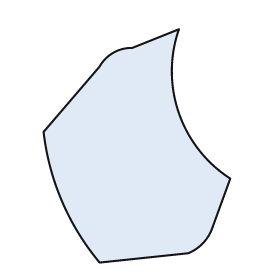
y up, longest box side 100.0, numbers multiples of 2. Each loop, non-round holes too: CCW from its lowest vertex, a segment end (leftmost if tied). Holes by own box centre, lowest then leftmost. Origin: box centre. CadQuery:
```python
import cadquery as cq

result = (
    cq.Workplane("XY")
    .moveTo(-16.0, -50.0)
    .lineTo(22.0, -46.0)
    .threePointArc((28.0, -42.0), (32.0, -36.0))
    .lineTo(40.0, -14.0)
    .threePointArc((18.0, 14.0), (18.0, 50.0))
    .lineTo(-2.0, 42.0)
    .threePointArc((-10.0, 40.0), (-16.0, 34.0))
    .lineTo(-40.0, 6.0)
    .threePointArc((-32.0, -24.0), (-16.0, -50.0))
    .close()
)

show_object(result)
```